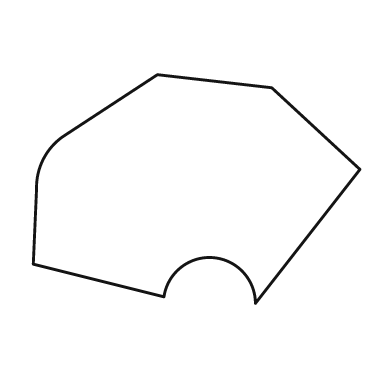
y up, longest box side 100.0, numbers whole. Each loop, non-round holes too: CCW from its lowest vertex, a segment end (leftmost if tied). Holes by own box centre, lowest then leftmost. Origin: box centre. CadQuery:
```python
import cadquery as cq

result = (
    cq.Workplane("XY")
    .moveTo(18.0, -35.0)
    .lineTo(50.0, 6.0)
    .lineTo(23.0, 31.0)
    .lineTo(-12.0, 35.0)
    .lineTo(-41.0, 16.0)
    .threePointArc((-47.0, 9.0), (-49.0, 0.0))
    .lineTo(-50.0, -23.0)
    .lineTo(-10.0, -33.0)
    .threePointArc((5.0, -21.0), (18.0, -35.0))
    .close()
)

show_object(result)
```